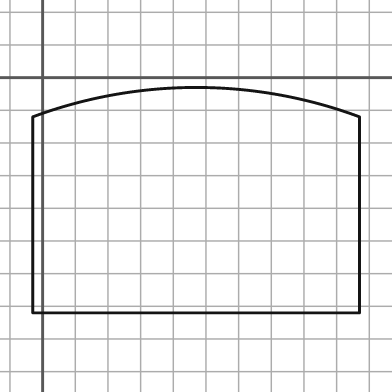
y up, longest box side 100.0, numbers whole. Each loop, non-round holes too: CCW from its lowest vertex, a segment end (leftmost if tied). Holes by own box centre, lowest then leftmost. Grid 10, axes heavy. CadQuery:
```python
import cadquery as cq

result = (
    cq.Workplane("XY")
    .moveTo(-3.0, -72.0)
    .lineTo(97.0, -72.0)
    .lineTo(97.0, -12.0)
    .threePointArc((47.0, -3.0), (-3.0, -12.0))
    .close()
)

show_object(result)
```